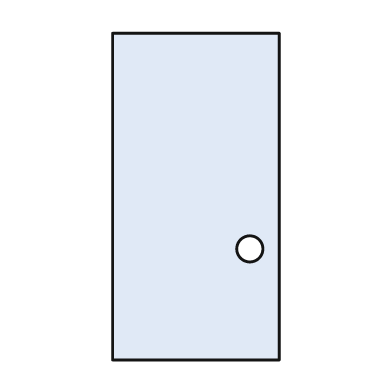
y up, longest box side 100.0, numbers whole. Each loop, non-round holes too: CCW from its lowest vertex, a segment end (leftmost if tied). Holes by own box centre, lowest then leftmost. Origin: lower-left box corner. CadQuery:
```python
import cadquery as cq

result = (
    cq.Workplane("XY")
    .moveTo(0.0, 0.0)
    .lineTo(51.0, 0.0)
    .lineTo(51.0, 100.0)
    .lineTo(0.0, 100.0)
    .close()
    .moveTo(42.0, 34.0)
    .circle(4.0)
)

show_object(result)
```